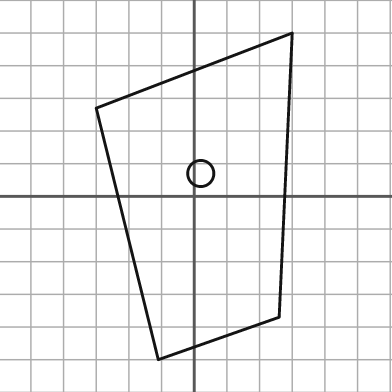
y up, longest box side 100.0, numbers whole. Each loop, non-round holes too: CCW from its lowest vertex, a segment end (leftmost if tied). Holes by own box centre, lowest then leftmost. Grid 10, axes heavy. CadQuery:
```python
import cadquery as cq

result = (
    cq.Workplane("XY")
    .moveTo(-11.0, -50.0)
    .lineTo(26.0, -37.0)
    .lineTo(30.0, 50.0)
    .lineTo(-30.0, 27.0)
    .close()
    .moveTo(2.0, 7.0)
    .circle(4.0)
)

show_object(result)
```